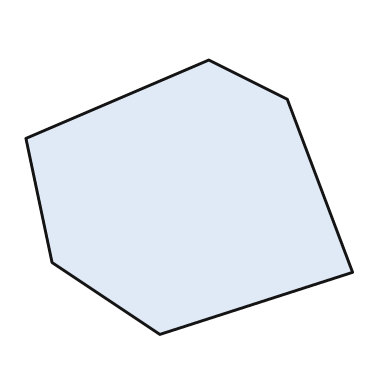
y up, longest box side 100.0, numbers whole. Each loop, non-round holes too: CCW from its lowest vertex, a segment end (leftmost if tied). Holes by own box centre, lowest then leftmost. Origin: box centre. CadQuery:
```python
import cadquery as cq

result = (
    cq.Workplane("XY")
    .moveTo(-9.0, -42.0)
    .lineTo(50.0, -23.0)
    .lineTo(30.0, 30.0)
    .lineTo(6.0, 42.0)
    .lineTo(-50.0, 18.0)
    .lineTo(-42.0, -20.0)
    .close()
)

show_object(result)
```